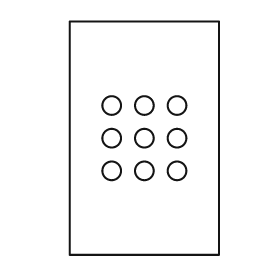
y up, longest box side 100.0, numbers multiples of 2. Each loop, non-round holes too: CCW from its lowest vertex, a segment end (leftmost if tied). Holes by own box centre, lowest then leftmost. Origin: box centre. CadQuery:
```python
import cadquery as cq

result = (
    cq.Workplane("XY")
    .moveTo(-32.0, -50.0)
    .lineTo(32.0, -50.0)
    .lineTo(32.0, 50.0)
    .lineTo(-32.0, 50.0)
    .close()
    .moveTo(-14.0, -14.0)
    .circle(4.0)
    .moveTo(0.0, -14.0)
    .circle(4.0)
    .moveTo(14.0, -14.0)
    .circle(4.0)
    .moveTo(-14.0, 0.0)
    .circle(4.0)
    .moveTo(0.0, 0.0)
    .circle(4.0)
    .moveTo(14.0, 0.0)
    .circle(4.0)
    .moveTo(-14.0, 14.0)
    .circle(4.0)
    .moveTo(0.0, 14.0)
    .circle(4.0)
    .moveTo(14.0, 14.0)
    .circle(4.0)
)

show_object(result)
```